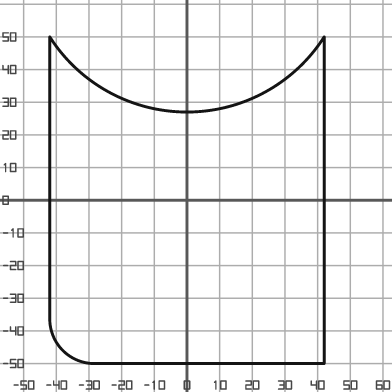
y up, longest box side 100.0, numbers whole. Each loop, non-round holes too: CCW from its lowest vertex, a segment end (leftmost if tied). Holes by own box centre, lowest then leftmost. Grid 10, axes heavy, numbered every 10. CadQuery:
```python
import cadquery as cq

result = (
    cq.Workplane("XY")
    .moveTo(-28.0, -50.0)
    .lineTo(42.0, -50.0)
    .lineTo(42.0, 50.0)
    .threePointArc((0.0, 27.0), (-42.0, 50.0))
    .lineTo(-42.0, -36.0)
    .threePointArc((-38.0, -46.0), (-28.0, -50.0))
    .close()
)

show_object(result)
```